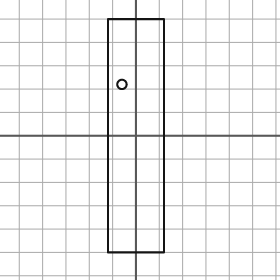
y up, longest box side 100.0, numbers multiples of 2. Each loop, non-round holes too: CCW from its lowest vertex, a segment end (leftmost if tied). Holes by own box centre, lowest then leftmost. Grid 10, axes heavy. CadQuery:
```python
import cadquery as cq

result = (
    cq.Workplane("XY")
    .moveTo(-12.0, -50.0)
    .lineTo(12.0, -50.0)
    .lineTo(12.0, 50.0)
    .lineTo(-12.0, 50.0)
    .close()
    .moveTo(-6.0, 22.0)
    .circle(2.0)
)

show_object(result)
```